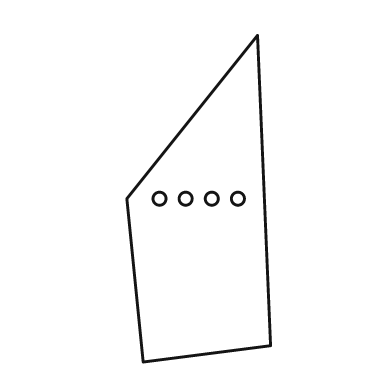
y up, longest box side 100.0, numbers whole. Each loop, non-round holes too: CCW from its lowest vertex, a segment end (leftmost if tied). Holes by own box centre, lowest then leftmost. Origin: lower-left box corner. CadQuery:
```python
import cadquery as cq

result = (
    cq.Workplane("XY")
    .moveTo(5.0, 0.0)
    .lineTo(44.0, 5.0)
    .lineTo(40.0, 100.0)
    .lineTo(0.0, 50.0)
    .close()
    .moveTo(10.0, 50.0)
    .circle(2.0)
    .moveTo(18.0, 50.0)
    .circle(2.0)
    .moveTo(26.0, 50.0)
    .circle(2.0)
    .moveTo(34.0, 50.0)
    .circle(2.0)
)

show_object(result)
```